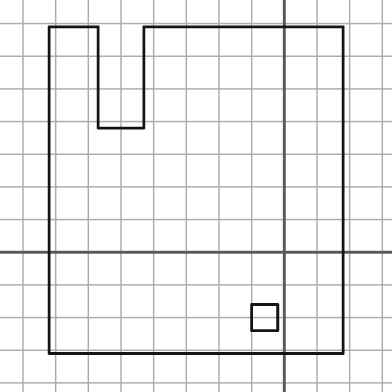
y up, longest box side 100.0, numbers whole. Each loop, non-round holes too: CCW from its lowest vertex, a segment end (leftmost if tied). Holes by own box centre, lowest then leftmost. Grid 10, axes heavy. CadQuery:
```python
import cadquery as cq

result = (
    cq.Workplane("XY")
    .moveTo(-72.0, -31.0)
    .lineTo(18.0, -31.0)
    .lineTo(18.0, 69.0)
    .lineTo(-43.0, 69.0)
    .lineTo(-43.0, 38.0)
    .lineTo(-57.0, 38.0)
    .lineTo(-57.0, 69.0)
    .lineTo(-72.0, 69.0)
    .close()
    .moveTo(-10.0, -24.0)
    .lineTo(-2.0, -24.0)
    .lineTo(-2.0, -16.0)
    .lineTo(-10.0, -16.0)
    .close()
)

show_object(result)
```